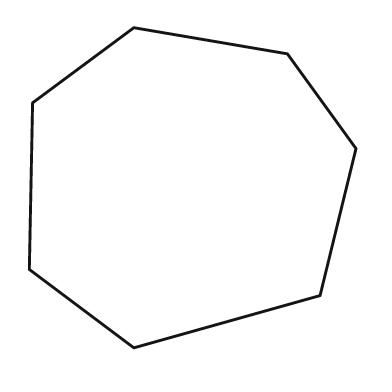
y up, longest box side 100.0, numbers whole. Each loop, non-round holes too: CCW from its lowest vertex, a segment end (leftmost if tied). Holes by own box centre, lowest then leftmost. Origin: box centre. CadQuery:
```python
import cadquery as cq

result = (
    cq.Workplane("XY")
    .moveTo(-18.0, -49.0)
    .lineTo(39.0, -33.0)
    .lineTo(50.0, 12.0)
    .lineTo(29.0, 41.0)
    .lineTo(-18.0, 49.0)
    .lineTo(-49.0, 26.0)
    .lineTo(-50.0, -25.0)
    .close()
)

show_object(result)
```